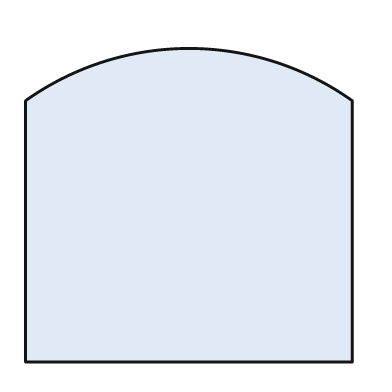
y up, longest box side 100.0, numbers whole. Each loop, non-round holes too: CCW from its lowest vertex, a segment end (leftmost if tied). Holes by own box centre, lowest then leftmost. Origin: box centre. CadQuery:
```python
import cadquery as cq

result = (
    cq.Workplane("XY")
    .moveTo(-50.0, -48.0)
    .lineTo(50.0, -48.0)
    .lineTo(50.0, 32.0)
    .threePointArc((0.0, 48.0), (-50.0, 32.0))
    .close()
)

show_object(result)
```